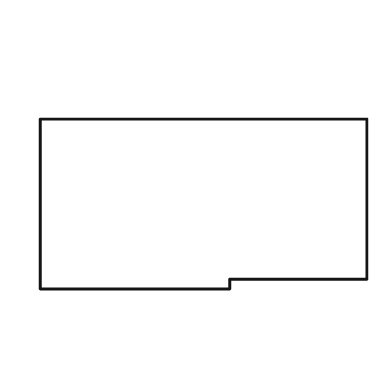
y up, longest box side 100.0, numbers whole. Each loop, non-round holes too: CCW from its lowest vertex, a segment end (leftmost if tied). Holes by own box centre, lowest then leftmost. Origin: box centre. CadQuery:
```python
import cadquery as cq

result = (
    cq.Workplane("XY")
    .moveTo(-50.0, -26.0)
    .lineTo(8.0, -26.0)
    .lineTo(8.0, -23.0)
    .lineTo(50.0, -23.0)
    .lineTo(50.0, 26.0)
    .lineTo(-50.0, 26.0)
    .close()
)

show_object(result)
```